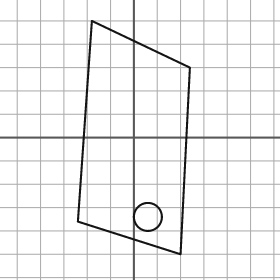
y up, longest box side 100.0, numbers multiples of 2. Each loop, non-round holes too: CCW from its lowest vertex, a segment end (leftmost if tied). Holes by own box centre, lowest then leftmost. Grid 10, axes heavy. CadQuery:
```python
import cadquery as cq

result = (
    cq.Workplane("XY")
    .moveTo(20.0, -50.0)
    .lineTo(24.0, 30.0)
    .lineTo(-18.0, 50.0)
    .lineTo(-24.0, -36.0)
    .close()
    .moveTo(6.0, -34.0)
    .circle(6.0)
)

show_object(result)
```